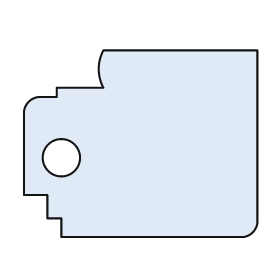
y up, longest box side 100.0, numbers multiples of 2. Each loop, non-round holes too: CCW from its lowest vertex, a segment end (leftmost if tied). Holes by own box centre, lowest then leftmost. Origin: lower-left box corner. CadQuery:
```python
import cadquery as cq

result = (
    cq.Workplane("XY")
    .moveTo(16.0, 0.0)
    .lineTo(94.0, 0.0)
    .threePointArc((98.0, 2.0), (100.0, 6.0))
    .lineTo(100.0, 80.0)
    .lineTo(34.0, 80.0)
    .threePointArc((32.0, 72.0), (34.0, 64.0))
    .lineTo(14.0, 64.0)
    .lineTo(14.0, 60.0)
    .lineTo(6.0, 60.0)
    .threePointArc((2.0, 58.0), (0.0, 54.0))
    .lineTo(0.0, 18.0)
    .lineTo(10.0, 18.0)
    .lineTo(10.0, 8.0)
    .lineTo(16.0, 8.0)
    .close()
    .moveTo(16.0, 34.0)
    .circle(8.0)
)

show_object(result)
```